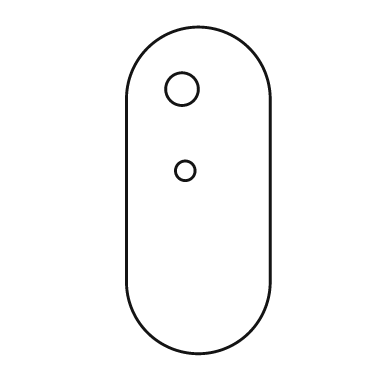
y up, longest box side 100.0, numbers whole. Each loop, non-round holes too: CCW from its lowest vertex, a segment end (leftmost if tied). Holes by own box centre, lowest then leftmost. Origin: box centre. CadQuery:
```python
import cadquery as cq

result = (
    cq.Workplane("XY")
    .moveTo(-22.0, -28.0)
    .threePointArc((0.0, -50.0), (22.0, -28.0))
    .lineTo(22.0, 28.0)
    .threePointArc((0.0, 50.0), (-22.0, 28.0))
    .close()
    .moveTo(-4.0, 6.0)
    .circle(3.0)
    .moveTo(-5.0, 31.0)
    .circle(5.0)
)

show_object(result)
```